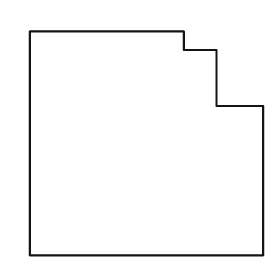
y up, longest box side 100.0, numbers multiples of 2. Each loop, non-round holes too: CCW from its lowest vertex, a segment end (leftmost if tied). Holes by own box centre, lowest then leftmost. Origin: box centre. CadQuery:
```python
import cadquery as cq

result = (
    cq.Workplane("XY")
    .moveTo(-50.0, -48.0)
    .lineTo(50.0, -48.0)
    .lineTo(50.0, 16.0)
    .lineTo(30.0, 16.0)
    .lineTo(30.0, 40.0)
    .lineTo(16.0, 40.0)
    .lineTo(16.0, 48.0)
    .lineTo(-50.0, 48.0)
    .close()
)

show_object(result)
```